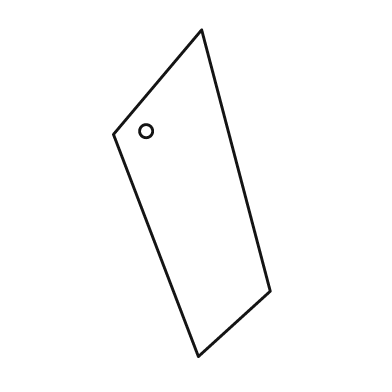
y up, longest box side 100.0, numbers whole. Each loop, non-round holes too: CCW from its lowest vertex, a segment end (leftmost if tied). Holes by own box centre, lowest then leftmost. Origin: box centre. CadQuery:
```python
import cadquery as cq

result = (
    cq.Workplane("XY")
    .moveTo(2.0, -50.0)
    .lineTo(24.0, -30.0)
    .lineTo(3.0, 50.0)
    .lineTo(-24.0, 18.0)
    .close()
    .moveTo(-14.0, 19.0)
    .circle(2.0)
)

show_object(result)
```